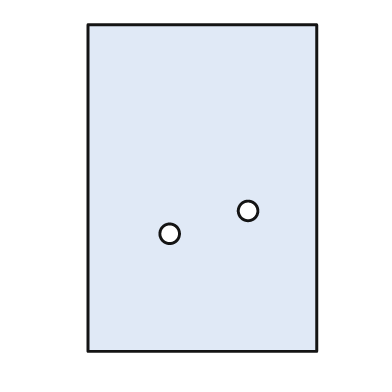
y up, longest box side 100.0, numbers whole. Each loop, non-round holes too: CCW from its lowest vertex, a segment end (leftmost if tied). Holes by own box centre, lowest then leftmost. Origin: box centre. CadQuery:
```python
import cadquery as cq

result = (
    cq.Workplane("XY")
    .moveTo(-35.0, -50.0)
    .lineTo(35.0, -50.0)
    .lineTo(35.0, 50.0)
    .lineTo(-35.0, 50.0)
    .close()
    .moveTo(-10.0, -14.0)
    .circle(3.0)
    .moveTo(14.0, -7.0)
    .circle(3.0)
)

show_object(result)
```